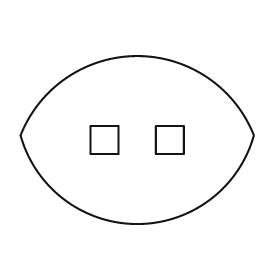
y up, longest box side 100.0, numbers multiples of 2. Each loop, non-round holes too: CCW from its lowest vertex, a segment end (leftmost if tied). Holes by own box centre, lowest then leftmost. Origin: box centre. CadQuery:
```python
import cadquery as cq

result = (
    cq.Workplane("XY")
    .moveTo(-50.0, 2.0)
    .threePointArc((0.0, -36.0), (50.0, 2.0))
    .threePointArc((0.0, 36.0), (-50.0, 2.0))
    .close()
    .moveTo(-20.0, -6.0)
    .lineTo(-8.0, -6.0)
    .lineTo(-8.0, 6.0)
    .lineTo(-20.0, 6.0)
    .close()
    .moveTo(8.0, -6.0)
    .lineTo(20.0, -6.0)
    .lineTo(20.0, 6.0)
    .lineTo(8.0, 6.0)
    .close()
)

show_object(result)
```